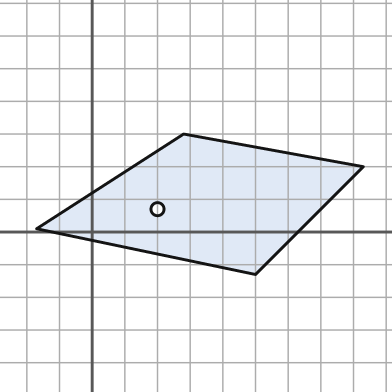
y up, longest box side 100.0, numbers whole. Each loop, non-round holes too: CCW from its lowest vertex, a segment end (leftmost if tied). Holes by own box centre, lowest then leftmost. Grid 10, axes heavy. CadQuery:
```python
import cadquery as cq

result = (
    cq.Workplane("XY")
    .moveTo(50.0, -13.0)
    .lineTo(83.0, 20.0)
    .lineTo(28.0, 30.0)
    .lineTo(-17.0, 1.0)
    .close()
    .moveTo(20.0, 7.0)
    .circle(2.0)
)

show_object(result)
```